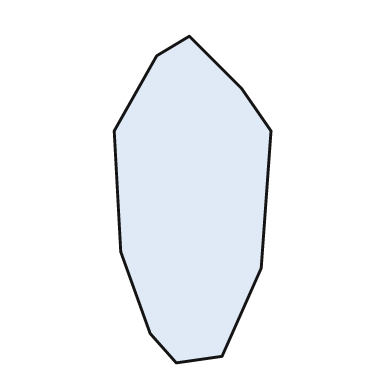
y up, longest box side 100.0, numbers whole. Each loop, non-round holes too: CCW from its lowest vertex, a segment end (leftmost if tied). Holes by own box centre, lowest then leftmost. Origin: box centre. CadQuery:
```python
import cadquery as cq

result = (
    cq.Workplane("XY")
    .moveTo(-5.0, -50.0)
    .lineTo(9.0, -48.0)
    .lineTo(21.0, -21.0)
    .lineTo(24.0, 21.0)
    .lineTo(15.0, 34.0)
    .lineTo(-1.0, 50.0)
    .lineTo(-11.0, 44.0)
    .lineTo(-24.0, 21.0)
    .lineTo(-22.0, -16.0)
    .lineTo(-13.0, -41.0)
    .close()
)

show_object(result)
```